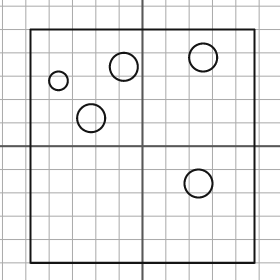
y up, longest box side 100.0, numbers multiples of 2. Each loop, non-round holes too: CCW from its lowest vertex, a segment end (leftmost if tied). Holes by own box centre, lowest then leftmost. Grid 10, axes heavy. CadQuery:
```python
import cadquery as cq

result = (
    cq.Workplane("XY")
    .moveTo(-48.0, -50.0)
    .lineTo(48.0, -50.0)
    .lineTo(48.0, 50.0)
    .lineTo(-48.0, 50.0)
    .close()
    .moveTo(24.0, -16.0)
    .circle(6.0)
    .moveTo(-22.0, 12.0)
    .circle(6.0)
    .moveTo(-36.0, 28.0)
    .circle(4.0)
    .moveTo(-8.0, 34.0)
    .circle(6.0)
    .moveTo(26.0, 38.0)
    .circle(6.0)
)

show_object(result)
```